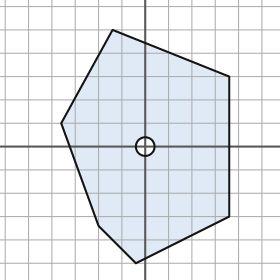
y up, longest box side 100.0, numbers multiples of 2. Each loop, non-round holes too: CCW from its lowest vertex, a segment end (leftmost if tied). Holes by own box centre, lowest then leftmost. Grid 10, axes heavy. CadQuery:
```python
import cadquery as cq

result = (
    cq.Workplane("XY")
    .moveTo(-4.0, -50.0)
    .lineTo(36.0, -30.0)
    .lineTo(36.0, 30.0)
    .lineTo(-14.0, 50.0)
    .lineTo(-36.0, 10.0)
    .lineTo(-20.0, -34.0)
    .close()
    .moveTo(0.0, 0.0)
    .circle(4.0)
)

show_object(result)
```